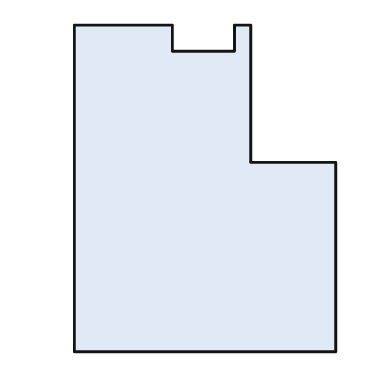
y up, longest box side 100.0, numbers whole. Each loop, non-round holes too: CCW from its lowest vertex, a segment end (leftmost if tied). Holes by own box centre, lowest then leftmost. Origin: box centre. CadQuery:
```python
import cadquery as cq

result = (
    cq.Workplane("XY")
    .moveTo(-40.0, -50.0)
    .lineTo(40.0, -50.0)
    .lineTo(40.0, 8.0)
    .lineTo(14.0, 8.0)
    .lineTo(14.0, 50.0)
    .lineTo(9.0, 50.0)
    .lineTo(9.0, 42.0)
    .lineTo(-10.0, 42.0)
    .lineTo(-10.0, 50.0)
    .lineTo(-40.0, 50.0)
    .close()
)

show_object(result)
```